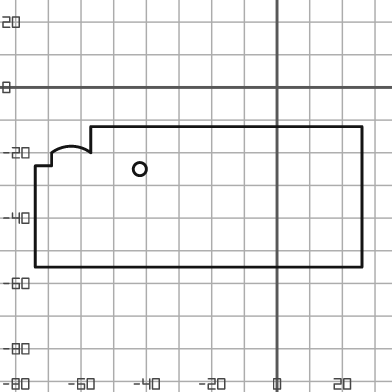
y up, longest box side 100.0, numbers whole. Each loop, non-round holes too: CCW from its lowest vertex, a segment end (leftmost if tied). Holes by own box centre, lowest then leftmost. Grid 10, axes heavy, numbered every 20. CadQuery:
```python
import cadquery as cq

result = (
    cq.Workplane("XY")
    .moveTo(-74.0, -55.0)
    .lineTo(26.0, -55.0)
    .lineTo(26.0, -12.0)
    .lineTo(-57.0, -12.0)
    .lineTo(-57.0, -20.0)
    .threePointArc((-63.0, -18.0), (-69.0, -20.0))
    .lineTo(-69.0, -24.0)
    .lineTo(-74.0, -24.0)
    .close()
    .moveTo(-42.0, -25.0)
    .circle(2.0)
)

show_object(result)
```